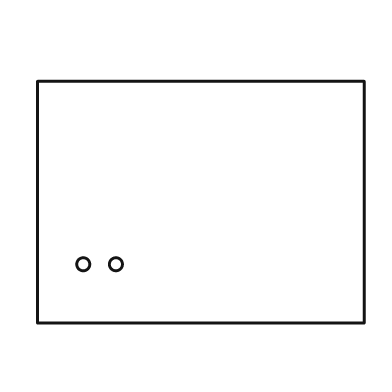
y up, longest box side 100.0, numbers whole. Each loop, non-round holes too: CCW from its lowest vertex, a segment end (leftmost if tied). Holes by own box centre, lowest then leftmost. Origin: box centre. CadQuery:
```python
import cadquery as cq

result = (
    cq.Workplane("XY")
    .moveTo(-50.0, -37.0)
    .lineTo(50.0, -37.0)
    .lineTo(50.0, 37.0)
    .lineTo(-50.0, 37.0)
    .close()
    .moveTo(-36.0, -19.0)
    .circle(2.0)
    .moveTo(-26.0, -19.0)
    .circle(2.0)
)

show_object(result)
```